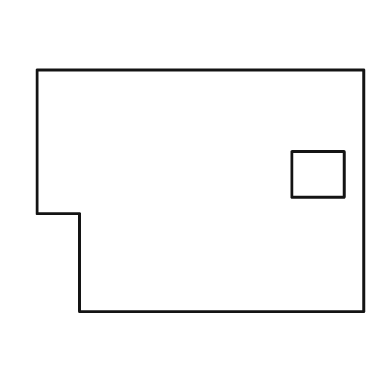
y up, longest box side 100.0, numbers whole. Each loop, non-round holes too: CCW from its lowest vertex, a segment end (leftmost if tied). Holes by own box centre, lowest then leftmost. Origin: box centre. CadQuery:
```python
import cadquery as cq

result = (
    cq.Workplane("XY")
    .moveTo(-37.0, -37.0)
    .lineTo(50.0, -37.0)
    .lineTo(50.0, 37.0)
    .lineTo(-50.0, 37.0)
    .lineTo(-50.0, -7.0)
    .lineTo(-37.0, -7.0)
    .close()
    .moveTo(28.0, -2.0)
    .lineTo(44.0, -2.0)
    .lineTo(44.0, 12.0)
    .lineTo(28.0, 12.0)
    .close()
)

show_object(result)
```